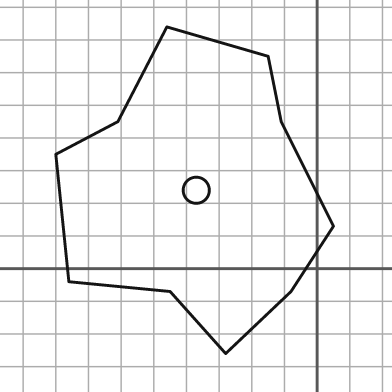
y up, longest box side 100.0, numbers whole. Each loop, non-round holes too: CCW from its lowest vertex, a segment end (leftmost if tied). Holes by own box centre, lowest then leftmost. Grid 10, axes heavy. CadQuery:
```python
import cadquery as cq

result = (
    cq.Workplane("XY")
    .moveTo(-28.0, -26.0)
    .lineTo(-8.0, -7.0)
    .lineTo(5.0, 13.0)
    .lineTo(-11.0, 45.0)
    .lineTo(-15.0, 65.0)
    .lineTo(-46.0, 74.0)
    .lineTo(-61.0, 45.0)
    .lineTo(-80.0, 35.0)
    .lineTo(-76.0, -4.0)
    .lineTo(-45.0, -7.0)
    .close()
    .moveTo(-37.0, 24.0)
    .circle(4.0)
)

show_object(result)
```